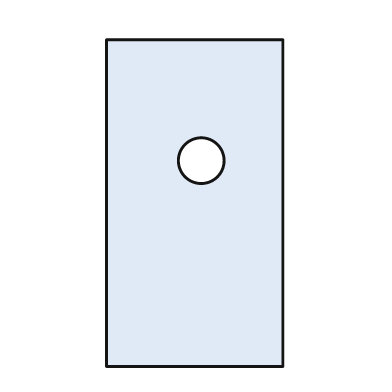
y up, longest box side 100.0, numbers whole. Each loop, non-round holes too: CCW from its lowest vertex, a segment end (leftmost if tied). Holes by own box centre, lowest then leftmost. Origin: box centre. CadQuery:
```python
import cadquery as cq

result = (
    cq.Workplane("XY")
    .moveTo(-27.0, -50.0)
    .lineTo(27.0, -50.0)
    .lineTo(27.0, 50.0)
    .lineTo(-27.0, 50.0)
    .close()
    .moveTo(2.0, 13.0)
    .circle(7.0)
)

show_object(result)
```